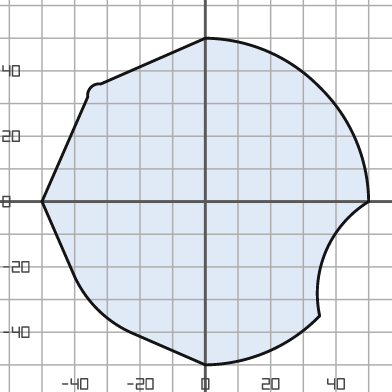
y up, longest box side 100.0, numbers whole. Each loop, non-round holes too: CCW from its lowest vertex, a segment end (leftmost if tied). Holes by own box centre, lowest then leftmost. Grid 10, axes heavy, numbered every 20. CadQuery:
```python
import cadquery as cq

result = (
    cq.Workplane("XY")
    .moveTo(0.0, -50.0)
    .threePointArc((19.0, -46.0), (35.0, -35.0))
    .threePointArc((37.0, -15.0), (50.0, 0.0))
    .threePointArc((46.0, 19.0), (35.0, 35.0))
    .threePointArc((19.0, 46.0), (0.0, 50.0))
    .lineTo(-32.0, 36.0)
    .threePointArc((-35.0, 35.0), (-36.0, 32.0))
    .lineTo(-50.0, 0.0)
    .lineTo(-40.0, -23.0)
    .threePointArc((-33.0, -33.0), (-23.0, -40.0))
    .close()
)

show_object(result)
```